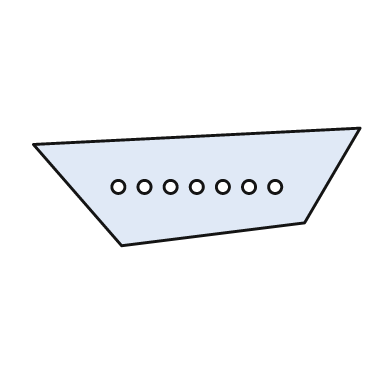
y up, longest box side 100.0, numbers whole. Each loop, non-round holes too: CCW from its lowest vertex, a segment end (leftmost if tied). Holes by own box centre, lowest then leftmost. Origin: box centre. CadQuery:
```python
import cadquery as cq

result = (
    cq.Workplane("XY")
    .moveTo(-23.0, -18.0)
    .lineTo(33.0, -11.0)
    .lineTo(50.0, 18.0)
    .lineTo(-50.0, 13.0)
    .close()
    .moveTo(-24.0, 0.0)
    .circle(2.0)
    .moveTo(-16.0, 0.0)
    .circle(2.0)
    .moveTo(-8.0, 0.0)
    .circle(2.0)
    .moveTo(0.0, 0.0)
    .circle(2.0)
    .moveTo(8.0, 0.0)
    .circle(2.0)
    .moveTo(16.0, 0.0)
    .circle(2.0)
    .moveTo(24.0, 0.0)
    .circle(2.0)
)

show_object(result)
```